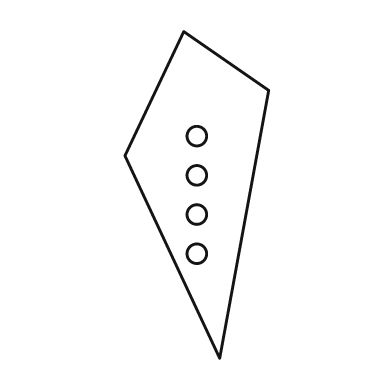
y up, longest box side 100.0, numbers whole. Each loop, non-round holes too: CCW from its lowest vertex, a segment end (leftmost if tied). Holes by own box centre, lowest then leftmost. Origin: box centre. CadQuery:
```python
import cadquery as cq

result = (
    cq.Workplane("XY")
    .moveTo(7.0, -50.0)
    .lineTo(22.0, 32.0)
    .lineTo(-4.0, 50.0)
    .lineTo(-22.0, 12.0)
    .close()
    .moveTo(0.0, -18.0)
    .circle(3.0)
    .moveTo(0.0, -6.0)
    .circle(3.0)
    .moveTo(0.0, 6.0)
    .circle(3.0)
    .moveTo(0.0, 18.0)
    .circle(3.0)
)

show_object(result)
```